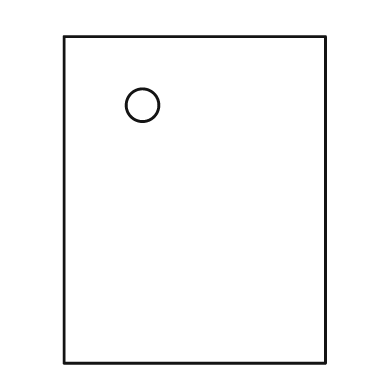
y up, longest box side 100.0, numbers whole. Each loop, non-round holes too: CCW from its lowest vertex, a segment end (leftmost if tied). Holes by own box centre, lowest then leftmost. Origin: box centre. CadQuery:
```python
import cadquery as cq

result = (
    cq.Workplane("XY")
    .moveTo(-40.0, -50.0)
    .lineTo(40.0, -50.0)
    .lineTo(40.0, 50.0)
    .lineTo(-40.0, 50.0)
    .close()
    .moveTo(-16.0, 29.0)
    .circle(5.0)
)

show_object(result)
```